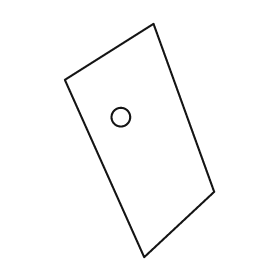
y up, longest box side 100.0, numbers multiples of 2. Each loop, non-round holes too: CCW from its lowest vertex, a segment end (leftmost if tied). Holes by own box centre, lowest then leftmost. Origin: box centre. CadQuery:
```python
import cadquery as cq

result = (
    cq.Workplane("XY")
    .moveTo(2.0, -50.0)
    .lineTo(32.0, -22.0)
    .lineTo(6.0, 50.0)
    .lineTo(-32.0, 26.0)
    .close()
    .moveTo(-8.0, 10.0)
    .circle(4.0)
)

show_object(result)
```